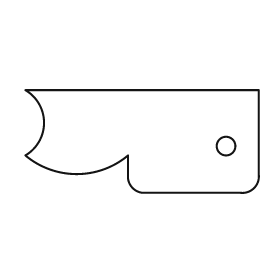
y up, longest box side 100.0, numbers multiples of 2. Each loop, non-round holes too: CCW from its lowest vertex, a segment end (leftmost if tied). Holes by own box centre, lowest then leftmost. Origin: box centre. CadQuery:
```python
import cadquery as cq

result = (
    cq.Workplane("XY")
    .moveTo(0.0, -22.0)
    .lineTo(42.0, -22.0)
    .threePointArc((48.0, -20.0), (50.0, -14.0))
    .lineTo(50.0, 22.0)
    .lineTo(-50.0, 22.0)
    .threePointArc((-42.0, 8.0), (-50.0, -6.0))
    .threePointArc((-28.0, -14.0), (-6.0, -6.0))
    .lineTo(-6.0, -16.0)
    .threePointArc((-4.0, -20.0), (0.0, -22.0))
    .close()
    .moveTo(36.0, -2.0)
    .circle(4.0)
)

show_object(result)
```